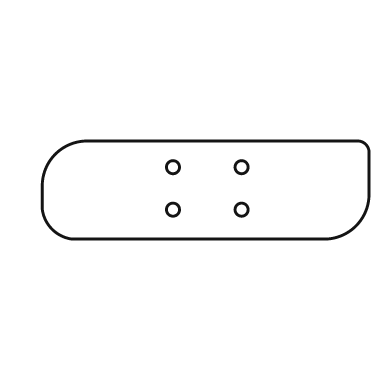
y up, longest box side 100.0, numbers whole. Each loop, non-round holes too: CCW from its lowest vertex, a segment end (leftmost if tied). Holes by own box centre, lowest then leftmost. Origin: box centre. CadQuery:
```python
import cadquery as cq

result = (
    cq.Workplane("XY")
    .moveTo(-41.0, -15.0)
    .lineTo(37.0, -15.0)
    .threePointArc((46.0, -11.0), (50.0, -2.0))
    .lineTo(50.0, 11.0)
    .threePointArc((49.0, 14.0), (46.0, 15.0))
    .lineTo(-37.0, 15.0)
    .threePointArc((-46.0, 11.0), (-50.0, 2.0))
    .lineTo(-50.0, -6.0)
    .threePointArc((-47.0, -12.0), (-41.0, -15.0))
    .close()
    .moveTo(-10.0, -6.0)
    .circle(2.0)
    .moveTo(11.0, -6.0)
    .circle(2.0)
    .moveTo(-10.0, 7.0)
    .circle(2.0)
    .moveTo(11.0, 7.0)
    .circle(2.0)
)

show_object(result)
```